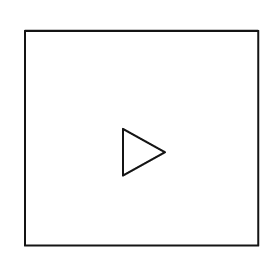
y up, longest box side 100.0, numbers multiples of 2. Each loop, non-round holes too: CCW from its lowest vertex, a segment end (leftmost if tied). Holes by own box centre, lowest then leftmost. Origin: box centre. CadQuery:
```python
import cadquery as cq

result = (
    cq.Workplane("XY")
    .moveTo(-50.0, -46.0)
    .lineTo(50.0, -46.0)
    .lineTo(50.0, 46.0)
    .lineTo(-50.0, 46.0)
    .close()
    .moveTo(-8.0, -16.0)
    .lineTo(10.0, -6.0)
    .lineTo(-8.0, 4.0)
    .close()
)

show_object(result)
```